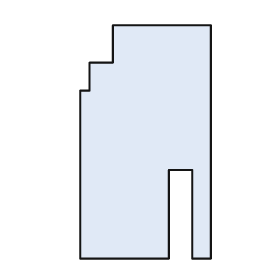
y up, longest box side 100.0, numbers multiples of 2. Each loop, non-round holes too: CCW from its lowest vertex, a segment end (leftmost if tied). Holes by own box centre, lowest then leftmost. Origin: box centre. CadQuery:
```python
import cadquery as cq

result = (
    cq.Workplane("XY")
    .moveTo(-28.0, -50.0)
    .lineTo(10.0, -50.0)
    .lineTo(10.0, -12.0)
    .lineTo(20.0, -12.0)
    .lineTo(20.0, -50.0)
    .lineTo(28.0, -50.0)
    .lineTo(28.0, 50.0)
    .lineTo(-14.0, 50.0)
    .lineTo(-14.0, 34.0)
    .lineTo(-24.0, 34.0)
    .lineTo(-24.0, 22.0)
    .lineTo(-28.0, 22.0)
    .close()
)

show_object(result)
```